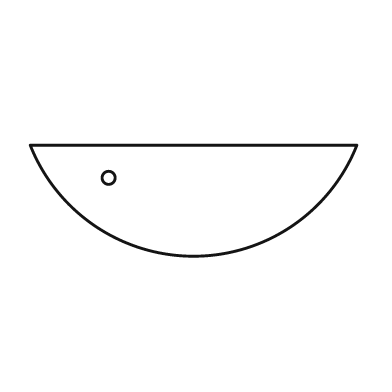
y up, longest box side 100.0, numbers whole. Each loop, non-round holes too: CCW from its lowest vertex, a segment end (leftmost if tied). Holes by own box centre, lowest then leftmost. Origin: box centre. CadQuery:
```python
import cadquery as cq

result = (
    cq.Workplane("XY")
    .moveTo(-50.0, 17.0)
    .threePointArc((0.0, -17.0), (50.0, 17.0))
    .close()
    .moveTo(-26.0, 7.0)
    .circle(2.0)
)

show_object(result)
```